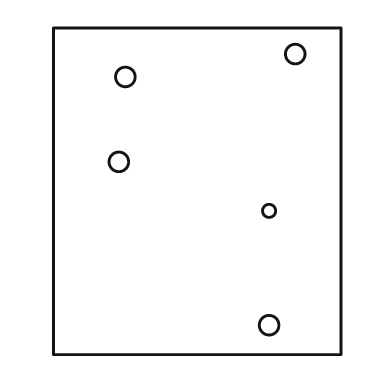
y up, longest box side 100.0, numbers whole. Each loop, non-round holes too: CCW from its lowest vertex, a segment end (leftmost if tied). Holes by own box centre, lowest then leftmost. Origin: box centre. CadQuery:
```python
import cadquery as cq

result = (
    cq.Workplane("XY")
    .moveTo(-44.0, -50.0)
    .lineTo(44.0, -50.0)
    .lineTo(44.0, 50.0)
    .lineTo(-44.0, 50.0)
    .close()
    .moveTo(22.0, -41.0)
    .circle(3.0)
    .moveTo(22.0, -6.0)
    .circle(2.0)
    .moveTo(-24.0, 9.0)
    .circle(3.0)
    .moveTo(-22.0, 35.0)
    .circle(3.0)
    .moveTo(30.0, 42.0)
    .circle(3.0)
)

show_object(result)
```